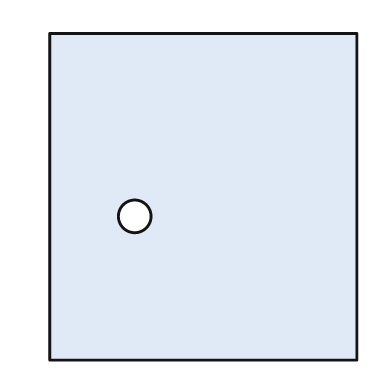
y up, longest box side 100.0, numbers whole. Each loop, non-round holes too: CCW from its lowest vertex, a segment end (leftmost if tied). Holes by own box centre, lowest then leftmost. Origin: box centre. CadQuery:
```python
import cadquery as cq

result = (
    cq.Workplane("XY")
    .moveTo(-47.0, -50.0)
    .lineTo(47.0, -50.0)
    .lineTo(47.0, 50.0)
    .lineTo(-47.0, 50.0)
    .close()
    .moveTo(-21.0, -6.0)
    .circle(5.0)
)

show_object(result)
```